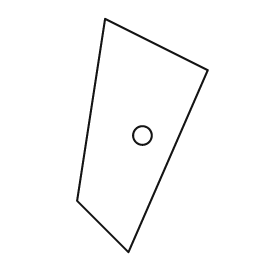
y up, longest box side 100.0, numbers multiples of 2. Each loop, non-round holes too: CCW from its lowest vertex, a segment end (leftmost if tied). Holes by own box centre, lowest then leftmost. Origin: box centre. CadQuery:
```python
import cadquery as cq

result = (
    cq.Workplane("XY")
    .moveTo(-6.0, -50.0)
    .lineTo(28.0, 28.0)
    .lineTo(-16.0, 50.0)
    .lineTo(-28.0, -28.0)
    .close()
    .moveTo(0.0, 0.0)
    .circle(4.0)
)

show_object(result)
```